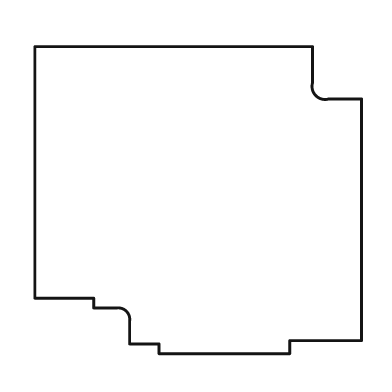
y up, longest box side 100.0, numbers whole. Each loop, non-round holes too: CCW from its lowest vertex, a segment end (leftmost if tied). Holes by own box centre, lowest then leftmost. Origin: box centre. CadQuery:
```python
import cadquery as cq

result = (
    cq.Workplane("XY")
    .moveTo(-12.0, -47.0)
    .lineTo(28.0, -47.0)
    .lineTo(28.0, -43.0)
    .lineTo(50.0, -43.0)
    .lineTo(50.0, 31.0)
    .lineTo(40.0, 31.0)
    .threePointArc((36.0, 32.0), (35.0, 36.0))
    .lineTo(35.0, 47.0)
    .lineTo(-50.0, 47.0)
    .lineTo(-50.0, -30.0)
    .lineTo(-32.0, -30.0)
    .lineTo(-32.0, -33.0)
    .lineTo(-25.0, -33.0)
    .threePointArc((-22.0, -34.0), (-21.0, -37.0))
    .lineTo(-21.0, -44.0)
    .lineTo(-12.0, -44.0)
    .close()
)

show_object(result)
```